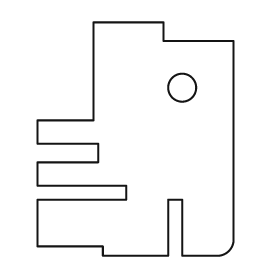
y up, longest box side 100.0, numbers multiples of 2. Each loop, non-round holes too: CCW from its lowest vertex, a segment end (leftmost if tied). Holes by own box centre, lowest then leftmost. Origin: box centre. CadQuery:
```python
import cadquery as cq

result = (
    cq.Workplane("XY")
    .moveTo(-14.0, -50.0)
    .lineTo(14.0, -50.0)
    .lineTo(14.0, -26.0)
    .lineTo(20.0, -26.0)
    .lineTo(20.0, -50.0)
    .lineTo(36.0, -50.0)
    .threePointArc((40.0, -48.0), (42.0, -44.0))
    .lineTo(42.0, 42.0)
    .lineTo(12.0, 42.0)
    .lineTo(12.0, 50.0)
    .lineTo(-18.0, 50.0)
    .lineTo(-18.0, 8.0)
    .lineTo(-42.0, 8.0)
    .lineTo(-42.0, -2.0)
    .lineTo(-16.0, -2.0)
    .lineTo(-16.0, -10.0)
    .lineTo(-42.0, -10.0)
    .lineTo(-42.0, -20.0)
    .lineTo(-4.0, -20.0)
    .lineTo(-4.0, -26.0)
    .lineTo(-42.0, -26.0)
    .lineTo(-42.0, -46.0)
    .lineTo(-14.0, -46.0)
    .close()
    .moveTo(20.0, 22.0)
    .circle(6.0)
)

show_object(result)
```